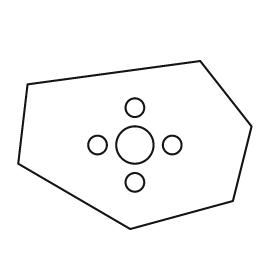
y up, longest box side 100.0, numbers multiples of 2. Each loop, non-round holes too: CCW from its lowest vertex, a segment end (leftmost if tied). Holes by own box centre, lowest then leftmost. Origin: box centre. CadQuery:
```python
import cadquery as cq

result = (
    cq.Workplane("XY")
    .moveTo(-2.0, -36.0)
    .lineTo(42.0, -24.0)
    .lineTo(50.0, 8.0)
    .lineTo(28.0, 36.0)
    .lineTo(-46.0, 26.0)
    .lineTo(-50.0, -8.0)
    .close()
    .moveTo(0.0, -16.0)
    .circle(4.0)
    .moveTo(-16.0, 0.0)
    .circle(4.0)
    .moveTo(0.0, 0.0)
    .circle(8.0)
    .moveTo(16.0, 0.0)
    .circle(4.0)
    .moveTo(0.0, 16.0)
    .circle(4.0)
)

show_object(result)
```